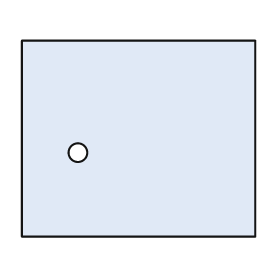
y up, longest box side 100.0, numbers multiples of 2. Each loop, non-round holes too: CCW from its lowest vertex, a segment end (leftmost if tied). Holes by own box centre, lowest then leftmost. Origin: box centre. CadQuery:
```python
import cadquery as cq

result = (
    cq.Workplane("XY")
    .moveTo(-50.0, -42.0)
    .lineTo(50.0, -42.0)
    .lineTo(50.0, 42.0)
    .lineTo(-50.0, 42.0)
    .close()
    .moveTo(-26.0, -6.0)
    .circle(4.0)
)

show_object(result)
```